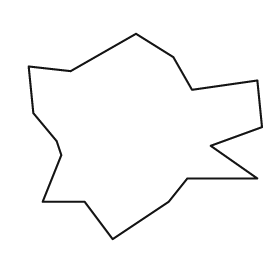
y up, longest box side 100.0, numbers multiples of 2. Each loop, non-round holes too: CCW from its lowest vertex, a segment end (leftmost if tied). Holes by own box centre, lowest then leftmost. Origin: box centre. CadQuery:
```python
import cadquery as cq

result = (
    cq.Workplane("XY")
    .moveTo(-14.0, -44.0)
    .lineTo(10.0, -28.0)
    .lineTo(18.0, -18.0)
    .lineTo(48.0, -18.0)
    .lineTo(28.0, -4.0)
    .lineTo(50.0, 4.0)
    .lineTo(48.0, 24.0)
    .lineTo(20.0, 20.0)
    .lineTo(12.0, 34.0)
    .lineTo(-4.0, 44.0)
    .lineTo(-32.0, 28.0)
    .lineTo(-50.0, 30.0)
    .lineTo(-48.0, 10.0)
    .lineTo(-38.0, -2.0)
    .lineTo(-36.0, -8.0)
    .lineTo(-44.0, -28.0)
    .lineTo(-26.0, -28.0)
    .close()
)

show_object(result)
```